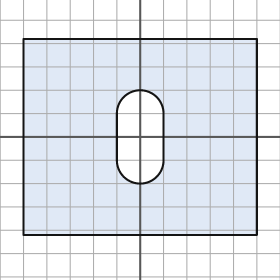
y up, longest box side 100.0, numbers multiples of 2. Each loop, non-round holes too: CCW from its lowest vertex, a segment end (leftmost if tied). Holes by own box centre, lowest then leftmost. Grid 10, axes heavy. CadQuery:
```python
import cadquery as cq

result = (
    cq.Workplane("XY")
    .moveTo(-50.0, -42.0)
    .lineTo(50.0, -42.0)
    .lineTo(50.0, 42.0)
    .lineTo(-50.0, 42.0)
    .close()
    .moveTo(-10.0, -10.0)
    .threePointArc((0.0, -20.0), (10.0, -10.0))
    .lineTo(10.0, 10.0)
    .threePointArc((0.0, 20.0), (-10.0, 10.0))
    .close()
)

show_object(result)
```